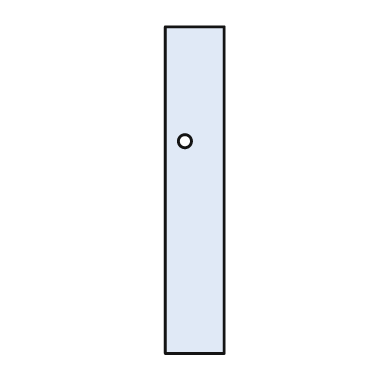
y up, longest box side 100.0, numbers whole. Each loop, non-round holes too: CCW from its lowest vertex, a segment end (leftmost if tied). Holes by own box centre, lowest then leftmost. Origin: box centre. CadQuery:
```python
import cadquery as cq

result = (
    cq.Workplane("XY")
    .moveTo(-9.0, -50.0)
    .lineTo(9.0, -50.0)
    .lineTo(9.0, 50.0)
    .lineTo(-9.0, 50.0)
    .close()
    .moveTo(-3.0, 15.0)
    .circle(2.0)
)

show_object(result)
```